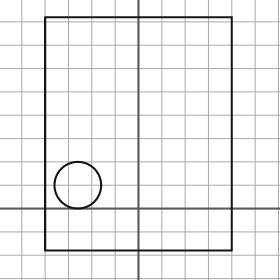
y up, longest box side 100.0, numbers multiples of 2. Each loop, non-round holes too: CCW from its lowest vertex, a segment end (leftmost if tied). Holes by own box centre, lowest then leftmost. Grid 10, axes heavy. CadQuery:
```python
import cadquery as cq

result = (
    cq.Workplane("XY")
    .moveTo(-40.0, -18.0)
    .lineTo(40.0, -18.0)
    .lineTo(40.0, 82.0)
    .lineTo(-40.0, 82.0)
    .close()
    .moveTo(-26.0, 10.0)
    .circle(10.0)
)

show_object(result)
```